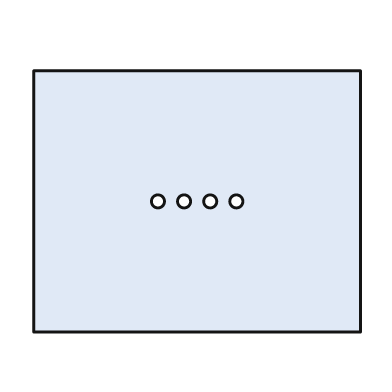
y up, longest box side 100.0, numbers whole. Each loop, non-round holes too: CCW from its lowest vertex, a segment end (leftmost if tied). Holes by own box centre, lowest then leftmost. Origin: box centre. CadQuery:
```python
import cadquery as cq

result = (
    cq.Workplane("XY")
    .moveTo(-50.0, -40.0)
    .lineTo(50.0, -40.0)
    .lineTo(50.0, 40.0)
    .lineTo(-50.0, 40.0)
    .close()
    .moveTo(-12.0, 0.0)
    .circle(2.0)
    .moveTo(-4.0, 0.0)
    .circle(2.0)
    .moveTo(4.0, 0.0)
    .circle(2.0)
    .moveTo(12.0, 0.0)
    .circle(2.0)
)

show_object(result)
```